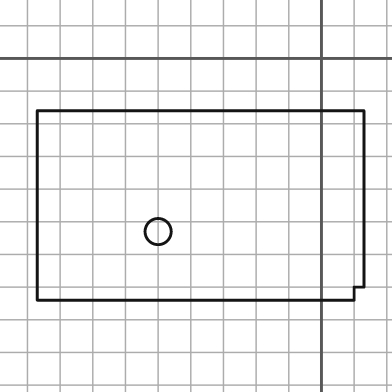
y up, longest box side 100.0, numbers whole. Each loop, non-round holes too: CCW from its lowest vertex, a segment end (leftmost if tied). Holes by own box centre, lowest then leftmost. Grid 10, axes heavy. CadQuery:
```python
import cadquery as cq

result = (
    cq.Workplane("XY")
    .moveTo(-87.0, -74.0)
    .lineTo(10.0, -74.0)
    .lineTo(10.0, -70.0)
    .lineTo(13.0, -70.0)
    .lineTo(13.0, -16.0)
    .lineTo(-87.0, -16.0)
    .close()
    .moveTo(-50.0, -53.0)
    .circle(4.0)
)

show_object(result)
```